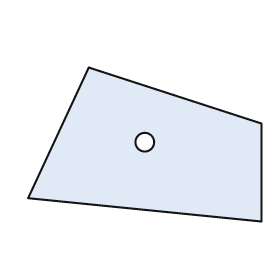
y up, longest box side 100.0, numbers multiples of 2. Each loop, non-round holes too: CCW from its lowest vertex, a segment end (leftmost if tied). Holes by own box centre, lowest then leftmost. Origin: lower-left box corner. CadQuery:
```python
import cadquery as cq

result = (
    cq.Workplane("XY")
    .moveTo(100.0, 0.0)
    .lineTo(100.0, 42.0)
    .lineTo(26.0, 66.0)
    .lineTo(0.0, 10.0)
    .close()
    .moveTo(50.0, 34.0)
    .circle(4.0)
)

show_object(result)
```